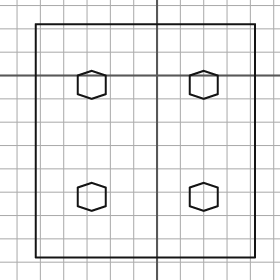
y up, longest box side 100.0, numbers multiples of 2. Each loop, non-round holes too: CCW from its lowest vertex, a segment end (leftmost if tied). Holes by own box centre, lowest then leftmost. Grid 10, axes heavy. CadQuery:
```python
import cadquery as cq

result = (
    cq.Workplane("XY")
    .moveTo(-52.0, -78.0)
    .lineTo(42.0, -78.0)
    .lineTo(42.0, 22.0)
    .lineTo(-52.0, 22.0)
    .close()
    .moveTo(-28.0, -58.0)
    .lineTo(-22.0, -56.0)
    .lineTo(-22.0, -48.0)
    .lineTo(-28.0, -46.0)
    .lineTo(-34.0, -48.0)
    .lineTo(-34.0, -56.0)
    .close()
    .moveTo(20.0, -58.0)
    .lineTo(26.0, -56.0)
    .lineTo(26.0, -48.0)
    .lineTo(20.0, -46.0)
    .lineTo(14.0, -48.0)
    .lineTo(14.0, -56.0)
    .close()
    .moveTo(-28.0, -10.0)
    .lineTo(-22.0, -8.0)
    .lineTo(-22.0, 0.0)
    .lineTo(-28.0, 2.0)
    .lineTo(-34.0, 0.0)
    .lineTo(-34.0, -8.0)
    .close()
    .moveTo(20.0, -10.0)
    .lineTo(26.0, -8.0)
    .lineTo(26.0, 0.0)
    .lineTo(20.0, 2.0)
    .lineTo(14.0, 0.0)
    .lineTo(14.0, -8.0)
    .close()
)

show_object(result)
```